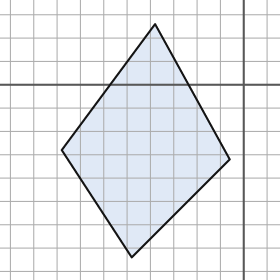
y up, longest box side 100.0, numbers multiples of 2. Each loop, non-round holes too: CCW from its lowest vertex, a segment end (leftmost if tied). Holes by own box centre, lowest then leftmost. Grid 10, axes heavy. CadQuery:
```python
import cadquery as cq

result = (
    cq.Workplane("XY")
    .moveTo(-48.0, -74.0)
    .lineTo(-6.0, -32.0)
    .lineTo(-38.0, 26.0)
    .lineTo(-78.0, -28.0)
    .close()
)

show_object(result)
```